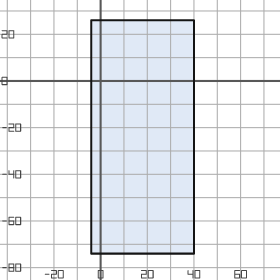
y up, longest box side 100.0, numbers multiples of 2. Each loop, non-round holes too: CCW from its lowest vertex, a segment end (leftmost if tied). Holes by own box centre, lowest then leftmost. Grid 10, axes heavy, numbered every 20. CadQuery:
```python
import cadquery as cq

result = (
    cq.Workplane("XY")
    .moveTo(-4.0, -74.0)
    .lineTo(40.0, -74.0)
    .lineTo(40.0, 26.0)
    .lineTo(-4.0, 26.0)
    .close()
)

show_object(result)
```